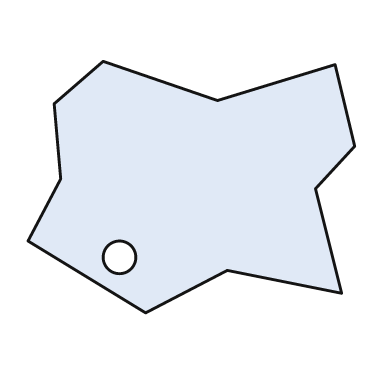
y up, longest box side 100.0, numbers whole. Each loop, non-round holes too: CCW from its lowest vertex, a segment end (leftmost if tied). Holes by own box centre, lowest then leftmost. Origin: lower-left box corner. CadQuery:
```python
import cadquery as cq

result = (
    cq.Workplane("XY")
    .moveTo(36.0, 0.0)
    .lineTo(61.0, 13.0)
    .lineTo(96.0, 6.0)
    .lineTo(88.0, 38.0)
    .lineTo(100.0, 51.0)
    .lineTo(94.0, 76.0)
    .lineTo(58.0, 65.0)
    .lineTo(23.0, 77.0)
    .lineTo(8.0, 64.0)
    .lineTo(10.0, 41.0)
    .lineTo(0.0, 22.0)
    .close()
    .moveTo(28.0, 17.0)
    .circle(5.0)
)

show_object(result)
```